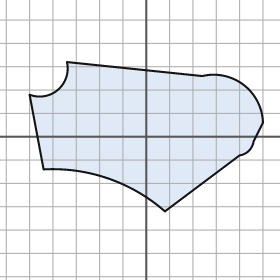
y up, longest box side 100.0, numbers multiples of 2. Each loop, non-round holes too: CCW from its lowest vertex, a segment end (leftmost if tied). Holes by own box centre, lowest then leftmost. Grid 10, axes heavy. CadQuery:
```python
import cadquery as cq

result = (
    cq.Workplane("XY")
    .moveTo(8.0, -32.0)
    .lineTo(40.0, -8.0)
    .threePointArc((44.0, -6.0), (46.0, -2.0))
    .lineTo(50.0, 6.0)
    .threePointArc((42.0, 22.0), (24.0, 26.0))
    .lineTo(-34.0, 32.0)
    .threePointArc((-38.0, 20.0), (-50.0, 18.0))
    .lineTo(-44.0, -14.0)
    .threePointArc((-16.0, -18.0), (8.0, -32.0))
    .close()
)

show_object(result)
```